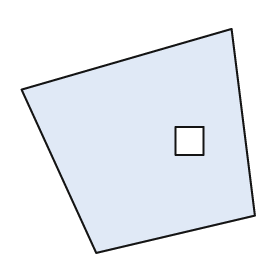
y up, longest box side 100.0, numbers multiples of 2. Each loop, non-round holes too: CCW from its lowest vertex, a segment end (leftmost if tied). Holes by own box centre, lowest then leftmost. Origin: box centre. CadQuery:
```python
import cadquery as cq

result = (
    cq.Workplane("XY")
    .moveTo(-18.0, -48.0)
    .lineTo(50.0, -32.0)
    .lineTo(40.0, 48.0)
    .lineTo(-50.0, 22.0)
    .close()
    .moveTo(16.0, -6.0)
    .lineTo(28.0, -6.0)
    .lineTo(28.0, 6.0)
    .lineTo(16.0, 6.0)
    .close()
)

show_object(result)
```